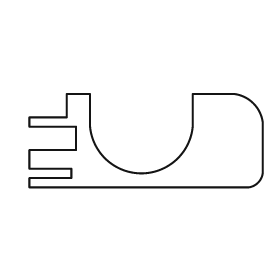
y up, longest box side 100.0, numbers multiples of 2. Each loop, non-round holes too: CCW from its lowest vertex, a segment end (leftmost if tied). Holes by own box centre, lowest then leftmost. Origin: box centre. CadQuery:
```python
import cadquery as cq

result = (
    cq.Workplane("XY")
    .moveTo(-50.0, -20.0)
    .lineTo(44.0, -20.0)
    .threePointArc((48.0, -18.0), (50.0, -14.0))
    .lineTo(50.0, 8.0)
    .threePointArc((46.0, 16.0), (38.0, 20.0))
    .lineTo(20.0, 20.0)
    .lineTo(20.0, 6.0)
    .threePointArc((-2.0, -14.0), (-24.0, 6.0))
    .lineTo(-24.0, 20.0)
    .lineTo(-34.0, 20.0)
    .lineTo(-34.0, 10.0)
    .lineTo(-50.0, 10.0)
    .lineTo(-50.0, 6.0)
    .lineTo(-30.0, 6.0)
    .lineTo(-30.0, -4.0)
    .lineTo(-50.0, -4.0)
    .lineTo(-50.0, -12.0)
    .lineTo(-32.0, -12.0)
    .lineTo(-32.0, -16.0)
    .lineTo(-50.0, -16.0)
    .close()
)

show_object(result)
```